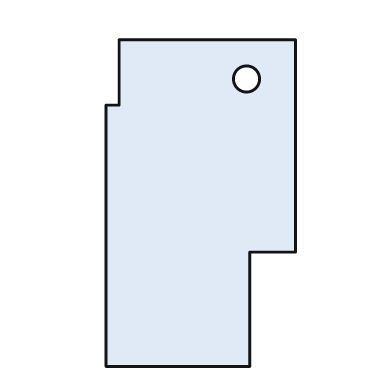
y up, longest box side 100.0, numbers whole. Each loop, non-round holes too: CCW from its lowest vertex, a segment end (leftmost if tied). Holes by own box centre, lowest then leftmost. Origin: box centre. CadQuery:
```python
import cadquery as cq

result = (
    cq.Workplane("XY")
    .moveTo(-29.0, -50.0)
    .lineTo(15.0, -50.0)
    .lineTo(15.0, -15.0)
    .lineTo(29.0, -15.0)
    .lineTo(29.0, 50.0)
    .lineTo(-25.0, 50.0)
    .lineTo(-25.0, 30.0)
    .lineTo(-29.0, 30.0)
    .close()
    .moveTo(14.0, 38.0)
    .circle(4.0)
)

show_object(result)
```